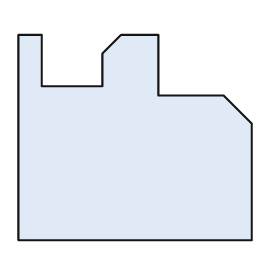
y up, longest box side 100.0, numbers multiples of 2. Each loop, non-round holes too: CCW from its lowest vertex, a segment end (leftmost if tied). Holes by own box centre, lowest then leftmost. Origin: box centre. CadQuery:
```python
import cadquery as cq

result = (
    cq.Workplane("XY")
    .moveTo(-50.0, -44.0)
    .lineTo(50.0, -44.0)
    .lineTo(50.0, 6.0)
    .lineTo(38.0, 18.0)
    .lineTo(10.0, 18.0)
    .lineTo(10.0, 44.0)
    .lineTo(-6.0, 44.0)
    .lineTo(-14.0, 36.0)
    .lineTo(-14.0, 22.0)
    .lineTo(-40.0, 22.0)
    .lineTo(-40.0, 44.0)
    .lineTo(-50.0, 44.0)
    .close()
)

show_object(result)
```